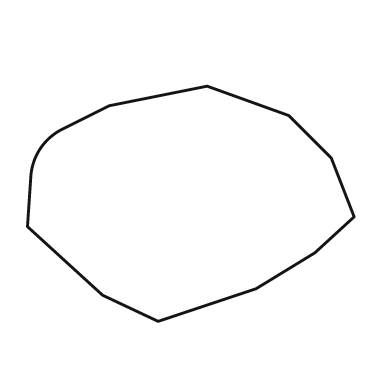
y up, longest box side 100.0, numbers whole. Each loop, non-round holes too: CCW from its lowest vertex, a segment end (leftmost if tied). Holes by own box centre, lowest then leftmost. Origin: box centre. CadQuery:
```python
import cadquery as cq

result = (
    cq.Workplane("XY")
    .moveTo(-10.0, -36.0)
    .lineTo(20.0, -26.0)
    .lineTo(38.0, -15.0)
    .lineTo(50.0, -4.0)
    .lineTo(43.0, 14.0)
    .lineTo(30.0, 27.0)
    .lineTo(5.0, 36.0)
    .lineTo(-25.0, 30.0)
    .lineTo(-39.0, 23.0)
    .threePointArc((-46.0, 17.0), (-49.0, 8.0))
    .lineTo(-50.0, -7.0)
    .lineTo(-27.0, -28.0)
    .close()
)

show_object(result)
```